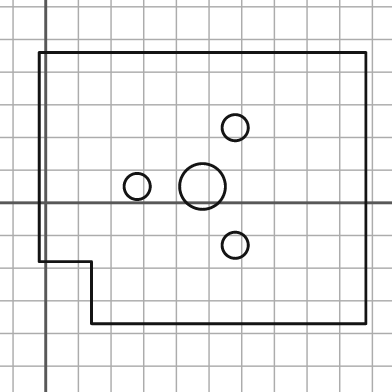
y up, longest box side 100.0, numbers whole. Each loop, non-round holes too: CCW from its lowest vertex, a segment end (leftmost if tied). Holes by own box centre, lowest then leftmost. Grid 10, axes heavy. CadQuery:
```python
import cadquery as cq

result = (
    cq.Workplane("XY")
    .moveTo(14.0, -37.0)
    .lineTo(98.0, -37.0)
    .lineTo(98.0, 46.0)
    .lineTo(-2.0, 46.0)
    .lineTo(-2.0, -18.0)
    .lineTo(14.0, -18.0)
    .close()
    .moveTo(58.0, -13.0)
    .circle(4.0)
    .moveTo(28.0, 5.0)
    .circle(4.0)
    .moveTo(48.0, 5.0)
    .circle(7.0)
    .moveTo(58.0, 23.0)
    .circle(4.0)
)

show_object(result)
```